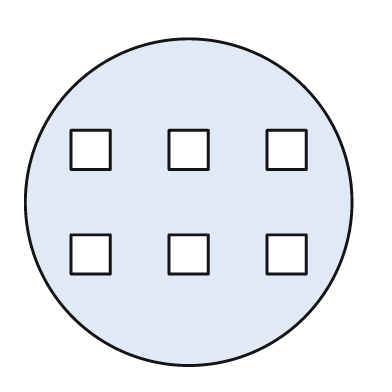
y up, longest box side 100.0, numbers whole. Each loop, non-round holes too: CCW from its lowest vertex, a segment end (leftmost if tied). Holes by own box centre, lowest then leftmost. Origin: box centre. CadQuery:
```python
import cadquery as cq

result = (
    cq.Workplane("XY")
    .moveTo(0.0, 0.0)
    .circle(50.0)
    .moveTo(-36.0, -22.0)
    .lineTo(-24.0, -22.0)
    .lineTo(-24.0, -10.0)
    .lineTo(-36.0, -10.0)
    .close()
    .moveTo(-6.0, -22.0)
    .lineTo(6.0, -22.0)
    .lineTo(6.0, -10.0)
    .lineTo(-6.0, -10.0)
    .close()
    .moveTo(24.0, -22.0)
    .lineTo(36.0, -22.0)
    .lineTo(36.0, -10.0)
    .lineTo(24.0, -10.0)
    .close()
    .moveTo(-36.0, 10.0)
    .lineTo(-24.0, 10.0)
    .lineTo(-24.0, 22.0)
    .lineTo(-36.0, 22.0)
    .close()
    .moveTo(-6.0, 10.0)
    .lineTo(6.0, 10.0)
    .lineTo(6.0, 22.0)
    .lineTo(-6.0, 22.0)
    .close()
    .moveTo(24.0, 10.0)
    .lineTo(36.0, 10.0)
    .lineTo(36.0, 22.0)
    .lineTo(24.0, 22.0)
    .close()
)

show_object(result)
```